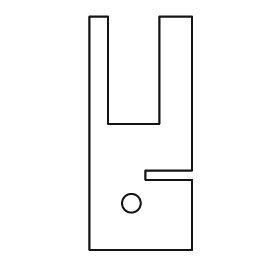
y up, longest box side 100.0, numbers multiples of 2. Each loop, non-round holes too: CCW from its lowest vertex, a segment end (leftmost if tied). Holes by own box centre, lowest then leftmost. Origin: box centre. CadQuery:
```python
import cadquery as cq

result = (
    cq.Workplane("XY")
    .moveTo(-22.0, -50.0)
    .lineTo(22.0, -50.0)
    .lineTo(22.0, -20.0)
    .lineTo(2.0, -20.0)
    .lineTo(2.0, -16.0)
    .lineTo(22.0, -16.0)
    .lineTo(22.0, 50.0)
    .lineTo(8.0, 50.0)
    .lineTo(8.0, 4.0)
    .lineTo(-14.0, 4.0)
    .lineTo(-14.0, 50.0)
    .lineTo(-22.0, 50.0)
    .close()
    .moveTo(-4.0, -30.0)
    .circle(4.0)
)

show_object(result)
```